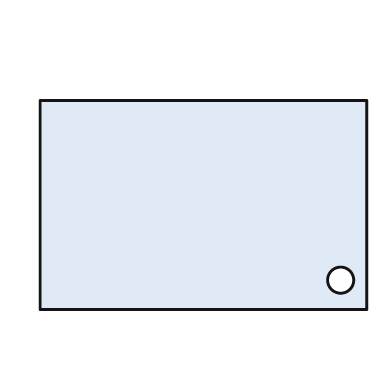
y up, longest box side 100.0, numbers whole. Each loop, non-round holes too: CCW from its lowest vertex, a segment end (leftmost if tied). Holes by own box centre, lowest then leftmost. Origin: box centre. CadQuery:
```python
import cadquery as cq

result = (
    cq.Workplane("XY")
    .moveTo(-50.0, -32.0)
    .lineTo(50.0, -32.0)
    .lineTo(50.0, 32.0)
    .lineTo(-50.0, 32.0)
    .close()
    .moveTo(42.0, -23.0)
    .circle(4.0)
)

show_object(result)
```